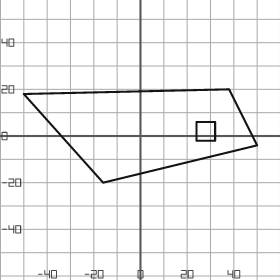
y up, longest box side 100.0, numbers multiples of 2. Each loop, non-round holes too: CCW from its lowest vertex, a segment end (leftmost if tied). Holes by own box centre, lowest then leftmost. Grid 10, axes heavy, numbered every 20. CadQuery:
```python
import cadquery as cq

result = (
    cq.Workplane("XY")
    .moveTo(-16.0, -20.0)
    .lineTo(50.0, -4.0)
    .lineTo(38.0, 20.0)
    .lineTo(-50.0, 18.0)
    .close()
    .moveTo(24.0, -2.0)
    .lineTo(32.0, -2.0)
    .lineTo(32.0, 6.0)
    .lineTo(24.0, 6.0)
    .close()
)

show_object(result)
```